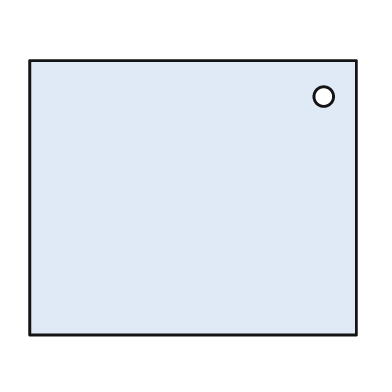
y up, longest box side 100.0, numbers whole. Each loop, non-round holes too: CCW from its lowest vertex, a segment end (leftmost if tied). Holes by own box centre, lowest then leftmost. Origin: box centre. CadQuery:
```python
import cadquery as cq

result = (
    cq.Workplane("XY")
    .moveTo(-50.0, -42.0)
    .lineTo(50.0, -42.0)
    .lineTo(50.0, 42.0)
    .lineTo(-50.0, 42.0)
    .close()
    .moveTo(40.0, 31.0)
    .circle(3.0)
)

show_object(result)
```